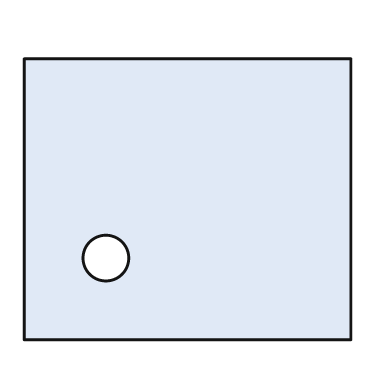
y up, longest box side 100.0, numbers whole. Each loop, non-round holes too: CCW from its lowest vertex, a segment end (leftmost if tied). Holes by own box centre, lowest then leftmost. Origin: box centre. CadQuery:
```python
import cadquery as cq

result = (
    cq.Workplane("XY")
    .moveTo(-50.0, -43.0)
    .lineTo(50.0, -43.0)
    .lineTo(50.0, 43.0)
    .lineTo(-50.0, 43.0)
    .close()
    .moveTo(-25.0, -18.0)
    .circle(7.0)
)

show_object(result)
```